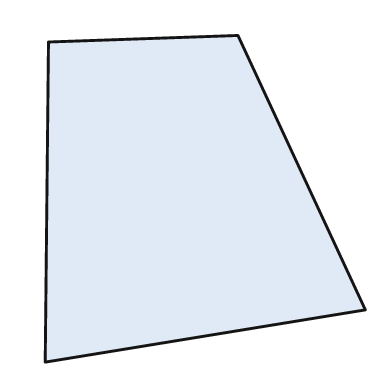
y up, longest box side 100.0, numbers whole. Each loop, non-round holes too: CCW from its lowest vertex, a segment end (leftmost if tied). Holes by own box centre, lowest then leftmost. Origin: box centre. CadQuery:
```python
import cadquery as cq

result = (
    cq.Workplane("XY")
    .moveTo(-49.0, -50.0)
    .lineTo(49.0, -34.0)
    .lineTo(10.0, 50.0)
    .lineTo(-48.0, 48.0)
    .close()
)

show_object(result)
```